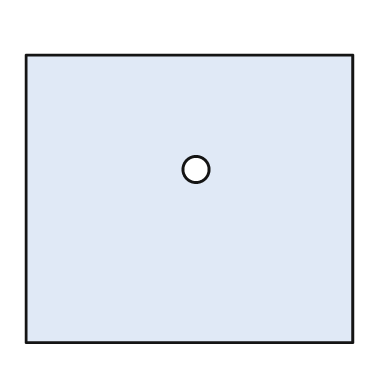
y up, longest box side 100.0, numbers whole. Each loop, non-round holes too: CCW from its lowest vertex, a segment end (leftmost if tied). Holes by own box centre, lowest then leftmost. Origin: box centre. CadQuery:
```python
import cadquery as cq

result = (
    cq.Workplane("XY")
    .moveTo(-50.0, -44.0)
    .lineTo(50.0, -44.0)
    .lineTo(50.0, 44.0)
    .lineTo(-50.0, 44.0)
    .close()
    .moveTo(2.0, 9.0)
    .circle(4.0)
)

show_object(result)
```